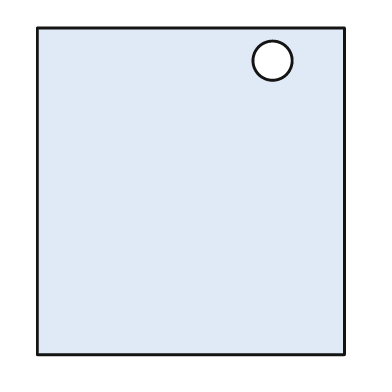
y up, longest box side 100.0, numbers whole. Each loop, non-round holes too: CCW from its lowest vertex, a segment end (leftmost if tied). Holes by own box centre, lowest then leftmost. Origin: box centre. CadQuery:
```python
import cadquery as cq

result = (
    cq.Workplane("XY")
    .moveTo(-47.0, -50.0)
    .lineTo(47.0, -50.0)
    .lineTo(47.0, 50.0)
    .lineTo(-47.0, 50.0)
    .close()
    .moveTo(25.0, 40.0)
    .circle(6.0)
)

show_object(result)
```